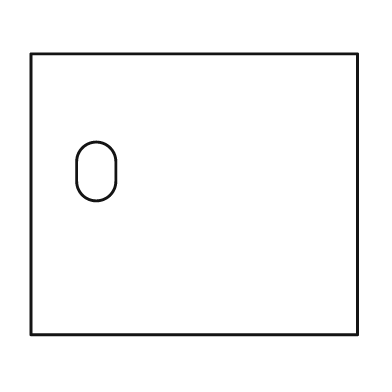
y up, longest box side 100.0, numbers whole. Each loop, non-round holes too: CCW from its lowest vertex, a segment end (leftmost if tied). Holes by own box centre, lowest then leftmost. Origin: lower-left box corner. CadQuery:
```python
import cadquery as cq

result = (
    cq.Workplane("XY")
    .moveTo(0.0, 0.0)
    .lineTo(100.0, 0.0)
    .lineTo(100.0, 86.0)
    .lineTo(0.0, 86.0)
    .close()
    .moveTo(14.0, 47.0)
    .threePointArc((20.0, 41.0), (26.0, 47.0))
    .lineTo(26.0, 53.0)
    .threePointArc((20.0, 59.0), (14.0, 53.0))
    .close()
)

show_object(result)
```